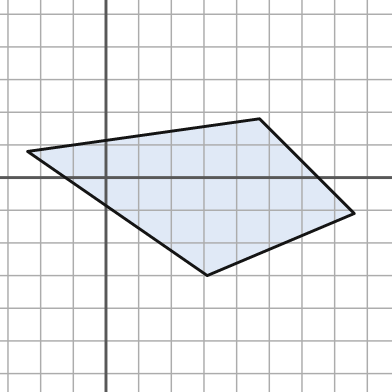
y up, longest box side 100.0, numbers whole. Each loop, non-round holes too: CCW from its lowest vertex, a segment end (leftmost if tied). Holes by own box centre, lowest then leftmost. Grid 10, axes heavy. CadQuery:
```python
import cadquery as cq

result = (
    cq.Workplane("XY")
    .moveTo(31.0, -30.0)
    .lineTo(76.0, -11.0)
    .lineTo(47.0, 18.0)
    .lineTo(-24.0, 8.0)
    .close()
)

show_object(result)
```